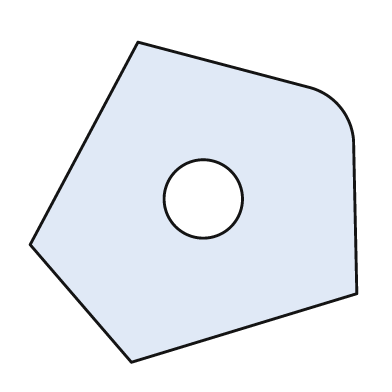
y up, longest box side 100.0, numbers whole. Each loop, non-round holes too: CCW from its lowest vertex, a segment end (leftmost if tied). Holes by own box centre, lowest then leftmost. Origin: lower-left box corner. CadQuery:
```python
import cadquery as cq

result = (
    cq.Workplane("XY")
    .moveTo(31.0, 0.0)
    .lineTo(100.0, 21.0)
    .lineTo(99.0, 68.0)
    .threePointArc((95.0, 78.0), (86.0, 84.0))
    .lineTo(33.0, 98.0)
    .lineTo(0.0, 36.0)
    .close()
    .moveTo(53.0, 50.0)
    .circle(12.0)
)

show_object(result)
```